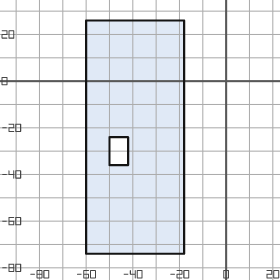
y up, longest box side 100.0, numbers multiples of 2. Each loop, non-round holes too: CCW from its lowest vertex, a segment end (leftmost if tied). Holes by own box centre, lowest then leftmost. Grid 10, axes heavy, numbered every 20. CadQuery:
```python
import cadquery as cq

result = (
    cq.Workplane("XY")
    .moveTo(-60.0, -74.0)
    .lineTo(-18.0, -74.0)
    .lineTo(-18.0, 26.0)
    .lineTo(-60.0, 26.0)
    .close()
    .moveTo(-50.0, -36.0)
    .lineTo(-42.0, -36.0)
    .lineTo(-42.0, -24.0)
    .lineTo(-50.0, -24.0)
    .close()
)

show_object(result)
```